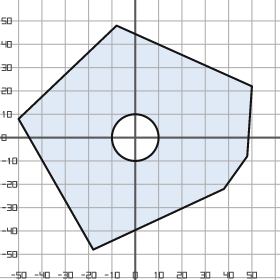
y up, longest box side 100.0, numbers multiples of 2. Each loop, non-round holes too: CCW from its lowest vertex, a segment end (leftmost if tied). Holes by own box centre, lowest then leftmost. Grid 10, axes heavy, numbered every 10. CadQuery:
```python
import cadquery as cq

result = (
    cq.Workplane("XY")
    .moveTo(-18.0, -48.0)
    .lineTo(38.0, -22.0)
    .lineTo(48.0, -8.0)
    .lineTo(50.0, 22.0)
    .lineTo(-8.0, 48.0)
    .lineTo(-50.0, 8.0)
    .close()
    .moveTo(0.0, 0.0)
    .circle(10.0)
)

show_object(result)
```